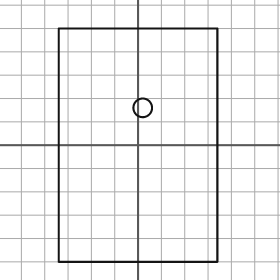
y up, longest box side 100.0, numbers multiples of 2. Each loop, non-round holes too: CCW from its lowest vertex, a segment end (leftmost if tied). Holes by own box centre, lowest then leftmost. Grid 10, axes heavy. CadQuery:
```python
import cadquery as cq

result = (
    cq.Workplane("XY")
    .moveTo(-34.0, -50.0)
    .lineTo(34.0, -50.0)
    .lineTo(34.0, 50.0)
    .lineTo(-34.0, 50.0)
    .close()
    .moveTo(2.0, 16.0)
    .circle(4.0)
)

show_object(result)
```